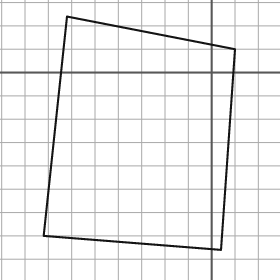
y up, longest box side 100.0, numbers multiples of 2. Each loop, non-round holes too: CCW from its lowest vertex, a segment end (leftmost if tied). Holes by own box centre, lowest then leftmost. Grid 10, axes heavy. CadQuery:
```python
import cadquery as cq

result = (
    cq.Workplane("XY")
    .moveTo(4.0, -76.0)
    .lineTo(10.0, 10.0)
    .lineTo(-62.0, 24.0)
    .lineTo(-72.0, -70.0)
    .close()
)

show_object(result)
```